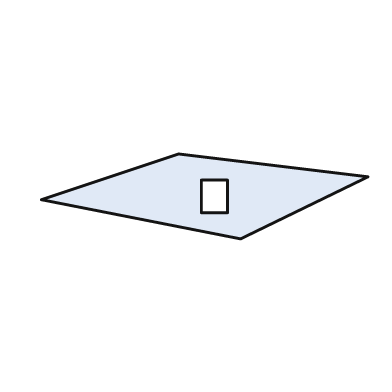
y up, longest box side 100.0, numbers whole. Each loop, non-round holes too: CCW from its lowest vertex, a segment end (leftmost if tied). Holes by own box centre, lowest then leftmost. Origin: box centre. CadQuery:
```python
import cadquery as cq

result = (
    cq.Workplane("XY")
    .moveTo(11.0, -13.0)
    .lineTo(50.0, 6.0)
    .lineTo(-8.0, 13.0)
    .lineTo(-50.0, -1.0)
    .close()
    .moveTo(-1.0, -5.0)
    .lineTo(7.0, -5.0)
    .lineTo(7.0, 5.0)
    .lineTo(-1.0, 5.0)
    .close()
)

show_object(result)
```